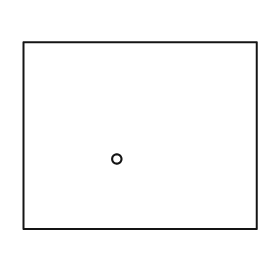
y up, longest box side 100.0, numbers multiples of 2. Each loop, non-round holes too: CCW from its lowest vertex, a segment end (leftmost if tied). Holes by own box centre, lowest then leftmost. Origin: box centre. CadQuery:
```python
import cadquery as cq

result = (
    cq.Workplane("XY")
    .moveTo(-50.0, -40.0)
    .lineTo(50.0, -40.0)
    .lineTo(50.0, 40.0)
    .lineTo(-50.0, 40.0)
    .close()
    .moveTo(-10.0, -10.0)
    .circle(2.0)
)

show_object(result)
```